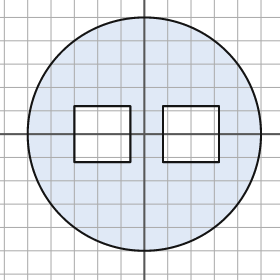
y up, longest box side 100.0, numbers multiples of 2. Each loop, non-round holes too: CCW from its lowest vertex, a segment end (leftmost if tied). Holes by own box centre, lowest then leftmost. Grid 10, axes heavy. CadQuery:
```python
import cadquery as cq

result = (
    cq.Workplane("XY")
    .moveTo(0.0, 0.0)
    .circle(50.0)
    .moveTo(-30.0, -12.0)
    .lineTo(-6.0, -12.0)
    .lineTo(-6.0, 12.0)
    .lineTo(-30.0, 12.0)
    .close()
    .moveTo(8.0, -12.0)
    .lineTo(32.0, -12.0)
    .lineTo(32.0, 12.0)
    .lineTo(8.0, 12.0)
    .close()
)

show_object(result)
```